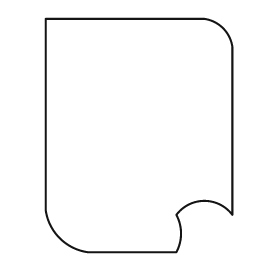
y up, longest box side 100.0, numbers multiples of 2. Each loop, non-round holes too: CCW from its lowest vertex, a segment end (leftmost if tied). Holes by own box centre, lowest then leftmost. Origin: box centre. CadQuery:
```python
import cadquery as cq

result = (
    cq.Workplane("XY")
    .moveTo(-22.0, -50.0)
    .lineTo(16.0, -50.0)
    .threePointArc((18.0, -42.0), (16.0, -34.0))
    .threePointArc((28.0, -28.0), (40.0, -34.0))
    .lineTo(40.0, 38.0)
    .threePointArc((36.0, 46.0), (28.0, 50.0))
    .lineTo(-40.0, 50.0)
    .lineTo(-40.0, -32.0)
    .threePointArc((-34.0, -44.0), (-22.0, -50.0))
    .close()
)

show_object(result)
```